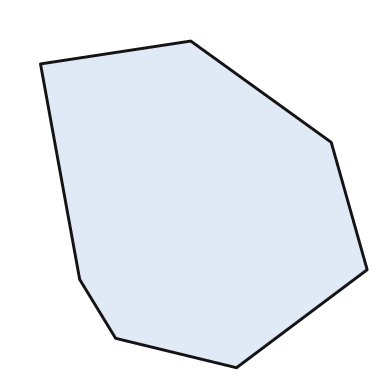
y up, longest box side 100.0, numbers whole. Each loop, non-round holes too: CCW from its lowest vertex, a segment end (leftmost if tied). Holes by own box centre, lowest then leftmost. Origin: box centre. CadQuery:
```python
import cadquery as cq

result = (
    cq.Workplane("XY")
    .moveTo(10.0, -50.0)
    .lineTo(50.0, -20.0)
    .lineTo(39.0, 19.0)
    .lineTo(-4.0, 50.0)
    .lineTo(-50.0, 43.0)
    .lineTo(-38.0, -23.0)
    .lineTo(-27.0, -41.0)
    .close()
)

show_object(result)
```